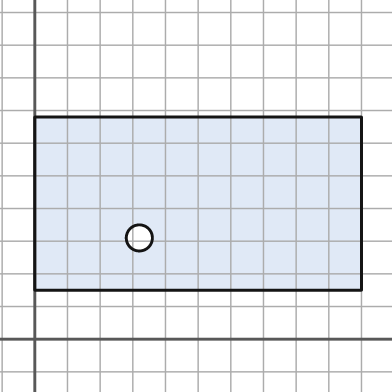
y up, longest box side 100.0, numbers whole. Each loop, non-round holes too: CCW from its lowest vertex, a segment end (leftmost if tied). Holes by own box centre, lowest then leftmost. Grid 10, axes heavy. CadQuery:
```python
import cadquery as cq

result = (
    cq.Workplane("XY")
    .moveTo(0.0, 15.0)
    .lineTo(100.0, 15.0)
    .lineTo(100.0, 68.0)
    .lineTo(0.0, 68.0)
    .close()
    .moveTo(32.0, 31.0)
    .circle(4.0)
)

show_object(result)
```